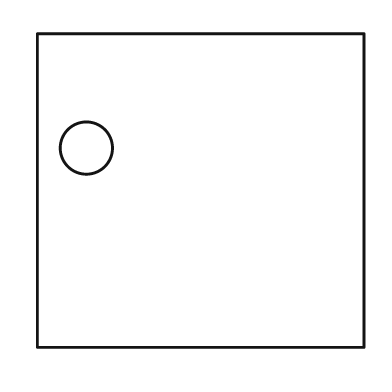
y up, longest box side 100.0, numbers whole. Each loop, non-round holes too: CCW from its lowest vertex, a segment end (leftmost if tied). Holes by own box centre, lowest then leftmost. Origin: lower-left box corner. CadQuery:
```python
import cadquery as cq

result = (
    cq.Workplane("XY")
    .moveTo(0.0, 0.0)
    .lineTo(100.0, 0.0)
    .lineTo(100.0, 96.0)
    .lineTo(0.0, 96.0)
    .close()
    .moveTo(15.0, 61.0)
    .circle(8.0)
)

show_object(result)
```